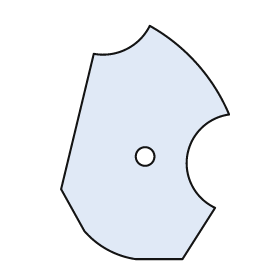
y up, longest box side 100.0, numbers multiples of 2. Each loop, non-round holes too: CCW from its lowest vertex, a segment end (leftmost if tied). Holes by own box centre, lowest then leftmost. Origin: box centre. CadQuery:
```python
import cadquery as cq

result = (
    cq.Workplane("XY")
    .moveTo(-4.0, -50.0)
    .lineTo(16.0, -50.0)
    .lineTo(30.0, -28.0)
    .threePointArc((18.0, -6.0), (36.0, 12.0))
    .threePointArc((22.0, 34.0), (2.0, 50.0))
    .threePointArc((-8.0, 40.0), (-22.0, 38.0))
    .lineTo(-36.0, -20.0)
    .lineTo(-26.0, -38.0)
    .threePointArc((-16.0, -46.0), (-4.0, -50.0))
    .close()
    .moveTo(0.0, -6.0)
    .circle(4.0)
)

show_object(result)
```